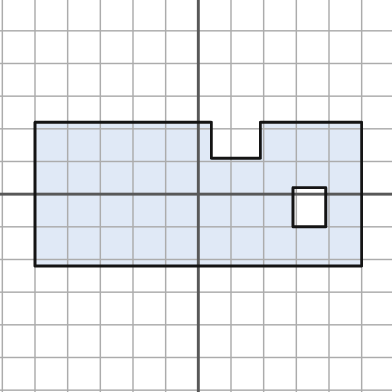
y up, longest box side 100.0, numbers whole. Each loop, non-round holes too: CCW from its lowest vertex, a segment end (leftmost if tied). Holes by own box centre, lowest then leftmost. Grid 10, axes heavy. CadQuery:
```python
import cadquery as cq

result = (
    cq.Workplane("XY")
    .moveTo(-50.0, -22.0)
    .lineTo(50.0, -22.0)
    .lineTo(50.0, 22.0)
    .lineTo(19.0, 22.0)
    .lineTo(19.0, 11.0)
    .lineTo(4.0, 11.0)
    .lineTo(4.0, 22.0)
    .lineTo(-50.0, 22.0)
    .close()
    .moveTo(29.0, -10.0)
    .lineTo(39.0, -10.0)
    .lineTo(39.0, 2.0)
    .lineTo(29.0, 2.0)
    .close()
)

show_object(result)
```